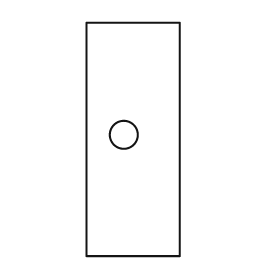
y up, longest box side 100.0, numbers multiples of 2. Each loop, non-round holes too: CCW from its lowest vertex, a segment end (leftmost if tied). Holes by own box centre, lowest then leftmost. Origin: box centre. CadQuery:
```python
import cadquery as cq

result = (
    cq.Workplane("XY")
    .moveTo(-20.0, -50.0)
    .lineTo(20.0, -50.0)
    .lineTo(20.0, 50.0)
    .lineTo(-20.0, 50.0)
    .close()
    .moveTo(-4.0, 2.0)
    .circle(6.0)
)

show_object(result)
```